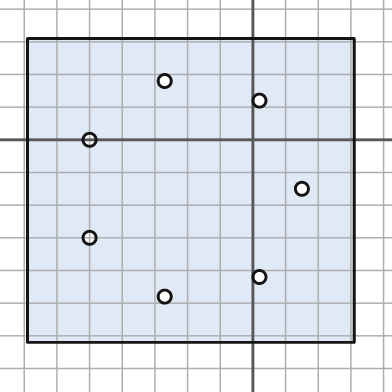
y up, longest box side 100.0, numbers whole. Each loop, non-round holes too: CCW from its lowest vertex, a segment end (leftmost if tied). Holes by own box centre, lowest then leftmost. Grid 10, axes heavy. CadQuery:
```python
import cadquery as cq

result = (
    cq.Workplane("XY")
    .moveTo(-69.0, -62.0)
    .lineTo(31.0, -62.0)
    .lineTo(31.0, 31.0)
    .lineTo(-69.0, 31.0)
    .close()
    .moveTo(-27.0, -48.0)
    .circle(2.0)
    .moveTo(2.0, -42.0)
    .circle(2.0)
    .moveTo(-50.0, -30.0)
    .circle(2.0)
    .moveTo(15.0, -15.0)
    .circle(2.0)
    .moveTo(-50.0, 0.0)
    .circle(2.0)
    .moveTo(2.0, 12.0)
    .circle(2.0)
    .moveTo(-27.0, 18.0)
    .circle(2.0)
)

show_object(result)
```